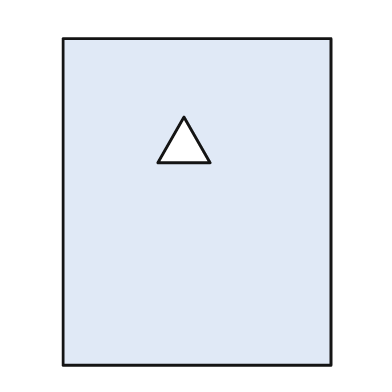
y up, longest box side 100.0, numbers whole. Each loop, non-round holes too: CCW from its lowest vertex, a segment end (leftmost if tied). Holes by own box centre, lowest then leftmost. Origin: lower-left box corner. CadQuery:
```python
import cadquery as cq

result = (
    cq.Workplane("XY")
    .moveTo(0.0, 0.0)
    .lineTo(82.0, 0.0)
    .lineTo(82.0, 100.0)
    .lineTo(0.0, 100.0)
    .close()
    .moveTo(29.0, 62.0)
    .lineTo(45.0, 62.0)
    .lineTo(37.0, 76.0)
    .close()
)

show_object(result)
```